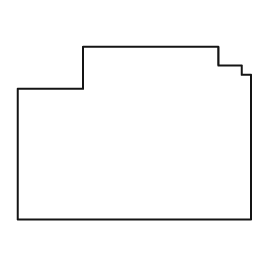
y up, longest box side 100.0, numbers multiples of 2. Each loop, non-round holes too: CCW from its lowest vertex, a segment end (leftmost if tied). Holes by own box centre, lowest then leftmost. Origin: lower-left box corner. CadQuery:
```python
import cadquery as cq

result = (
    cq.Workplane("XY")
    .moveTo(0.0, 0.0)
    .lineTo(100.0, 0.0)
    .lineTo(100.0, 62.0)
    .lineTo(96.0, 62.0)
    .lineTo(96.0, 66.0)
    .lineTo(86.0, 66.0)
    .lineTo(86.0, 74.0)
    .lineTo(28.0, 74.0)
    .lineTo(28.0, 56.0)
    .lineTo(0.0, 56.0)
    .close()
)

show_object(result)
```